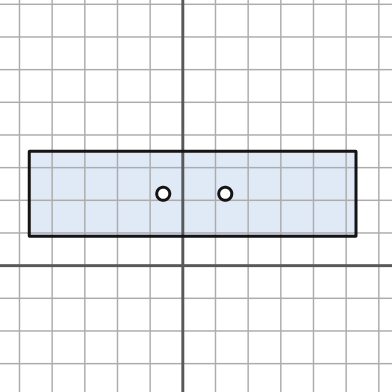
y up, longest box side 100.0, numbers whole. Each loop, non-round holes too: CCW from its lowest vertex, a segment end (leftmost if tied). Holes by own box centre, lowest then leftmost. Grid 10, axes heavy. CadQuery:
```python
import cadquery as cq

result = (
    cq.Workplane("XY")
    .moveTo(-47.0, 9.0)
    .lineTo(53.0, 9.0)
    .lineTo(53.0, 35.0)
    .lineTo(-47.0, 35.0)
    .close()
    .moveTo(-6.0, 22.0)
    .circle(2.0)
    .moveTo(13.0, 22.0)
    .circle(2.0)
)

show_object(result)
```